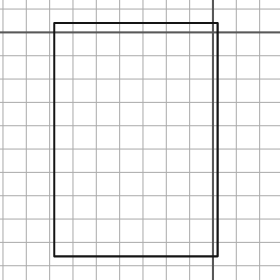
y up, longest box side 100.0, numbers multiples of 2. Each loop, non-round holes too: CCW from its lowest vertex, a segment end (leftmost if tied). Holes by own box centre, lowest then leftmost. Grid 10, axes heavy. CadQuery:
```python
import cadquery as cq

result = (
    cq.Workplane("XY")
    .moveTo(-68.0, -96.0)
    .lineTo(2.0, -96.0)
    .lineTo(2.0, 4.0)
    .lineTo(-68.0, 4.0)
    .close()
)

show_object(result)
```